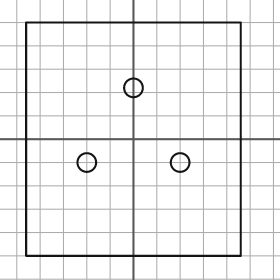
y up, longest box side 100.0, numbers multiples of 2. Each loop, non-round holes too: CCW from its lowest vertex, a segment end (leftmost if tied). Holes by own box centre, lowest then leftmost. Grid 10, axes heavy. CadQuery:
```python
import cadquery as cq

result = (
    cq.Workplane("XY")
    .moveTo(-46.0, -50.0)
    .lineTo(46.0, -50.0)
    .lineTo(46.0, 50.0)
    .lineTo(-46.0, 50.0)
    .close()
    .moveTo(-20.0, -10.0)
    .circle(4.0)
    .moveTo(20.0, -10.0)
    .circle(4.0)
    .moveTo(0.0, 22.0)
    .circle(4.0)
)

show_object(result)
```